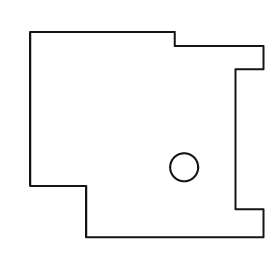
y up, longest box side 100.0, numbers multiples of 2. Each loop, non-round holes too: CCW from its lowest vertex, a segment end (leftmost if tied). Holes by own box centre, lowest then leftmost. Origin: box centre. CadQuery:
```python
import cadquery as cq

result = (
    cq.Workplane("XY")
    .moveTo(-26.0, -44.0)
    .lineTo(50.0, -44.0)
    .lineTo(50.0, -32.0)
    .lineTo(38.0, -32.0)
    .lineTo(38.0, 28.0)
    .lineTo(50.0, 28.0)
    .lineTo(50.0, 38.0)
    .lineTo(12.0, 38.0)
    .lineTo(12.0, 44.0)
    .lineTo(-50.0, 44.0)
    .lineTo(-50.0, -22.0)
    .lineTo(-26.0, -22.0)
    .close()
    .moveTo(16.0, -14.0)
    .circle(6.0)
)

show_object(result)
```